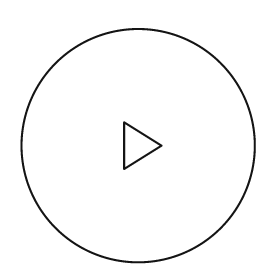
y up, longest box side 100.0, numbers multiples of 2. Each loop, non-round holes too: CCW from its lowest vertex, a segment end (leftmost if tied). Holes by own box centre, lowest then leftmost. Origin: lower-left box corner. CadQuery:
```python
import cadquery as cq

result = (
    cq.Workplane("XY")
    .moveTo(50.0, 50.0)
    .circle(50.0)
    .moveTo(44.0, 40.0)
    .lineTo(60.0, 50.0)
    .lineTo(44.0, 60.0)
    .close()
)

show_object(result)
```